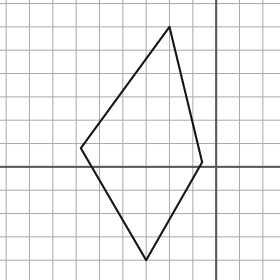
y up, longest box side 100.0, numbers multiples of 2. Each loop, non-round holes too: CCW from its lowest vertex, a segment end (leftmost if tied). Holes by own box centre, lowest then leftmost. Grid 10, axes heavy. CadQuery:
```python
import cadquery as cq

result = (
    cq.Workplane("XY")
    .moveTo(-30.0, -40.0)
    .lineTo(-6.0, 2.0)
    .lineTo(-20.0, 60.0)
    .lineTo(-58.0, 8.0)
    .close()
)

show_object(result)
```